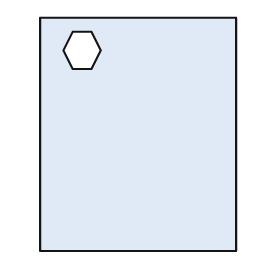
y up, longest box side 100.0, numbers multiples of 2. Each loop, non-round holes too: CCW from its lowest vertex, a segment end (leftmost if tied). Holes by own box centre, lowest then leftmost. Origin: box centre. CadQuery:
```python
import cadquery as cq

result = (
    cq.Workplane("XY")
    .moveTo(-42.0, -50.0)
    .lineTo(42.0, -50.0)
    .lineTo(42.0, 50.0)
    .lineTo(-42.0, 50.0)
    .close()
    .moveTo(-28.0, 28.0)
    .lineTo(-20.0, 28.0)
    .lineTo(-16.0, 36.0)
    .lineTo(-20.0, 44.0)
    .lineTo(-28.0, 44.0)
    .lineTo(-32.0, 36.0)
    .close()
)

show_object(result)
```